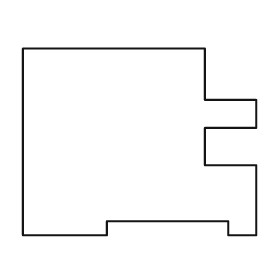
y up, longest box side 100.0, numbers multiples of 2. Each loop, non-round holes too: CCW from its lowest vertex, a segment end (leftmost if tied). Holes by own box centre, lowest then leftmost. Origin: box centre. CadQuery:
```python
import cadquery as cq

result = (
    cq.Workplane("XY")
    .moveTo(-50.0, -40.0)
    .lineTo(-14.0, -40.0)
    .lineTo(-14.0, -34.0)
    .lineTo(38.0, -34.0)
    .lineTo(38.0, -40.0)
    .lineTo(50.0, -40.0)
    .lineTo(50.0, -10.0)
    .lineTo(28.0, -10.0)
    .lineTo(28.0, 6.0)
    .lineTo(50.0, 6.0)
    .lineTo(50.0, 18.0)
    .lineTo(28.0, 18.0)
    .lineTo(28.0, 40.0)
    .lineTo(-50.0, 40.0)
    .close()
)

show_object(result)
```